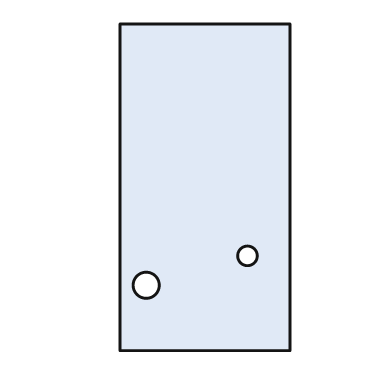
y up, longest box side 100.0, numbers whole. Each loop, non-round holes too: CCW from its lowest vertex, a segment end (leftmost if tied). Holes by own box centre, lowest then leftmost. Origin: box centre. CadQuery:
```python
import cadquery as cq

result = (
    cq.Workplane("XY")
    .moveTo(-26.0, -50.0)
    .lineTo(26.0, -50.0)
    .lineTo(26.0, 50.0)
    .lineTo(-26.0, 50.0)
    .close()
    .moveTo(-18.0, -30.0)
    .circle(4.0)
    .moveTo(13.0, -21.0)
    .circle(3.0)
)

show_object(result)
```